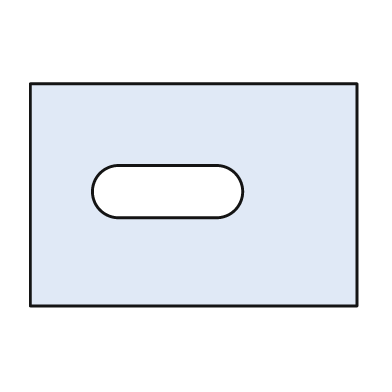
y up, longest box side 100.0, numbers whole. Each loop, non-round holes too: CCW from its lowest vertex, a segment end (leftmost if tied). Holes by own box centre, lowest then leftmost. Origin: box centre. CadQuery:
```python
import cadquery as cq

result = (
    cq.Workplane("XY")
    .moveTo(-50.0, -34.0)
    .lineTo(50.0, -34.0)
    .lineTo(50.0, 34.0)
    .lineTo(-50.0, 34.0)
    .close()
    .moveTo(-23.0, -7.0)
    .lineTo(7.0, -7.0)
    .threePointArc((15.0, 1.0), (7.0, 9.0))
    .lineTo(-23.0, 9.0)
    .threePointArc((-31.0, 1.0), (-23.0, -7.0))
    .close()
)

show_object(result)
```